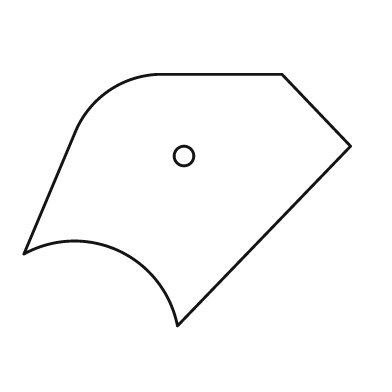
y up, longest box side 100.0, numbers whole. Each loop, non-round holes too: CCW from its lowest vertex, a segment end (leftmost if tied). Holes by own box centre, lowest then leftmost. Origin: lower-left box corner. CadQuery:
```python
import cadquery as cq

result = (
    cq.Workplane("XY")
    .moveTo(47.0, 0.0)
    .lineTo(100.0, 55.0)
    .lineTo(79.0, 77.0)
    .lineTo(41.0, 77.0)
    .threePointArc((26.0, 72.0), (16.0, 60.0))
    .lineTo(0.0, 22.0)
    .threePointArc((29.0, 23.0), (47.0, 0.0))
    .close()
    .moveTo(49.0, 52.0)
    .circle(3.0)
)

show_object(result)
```